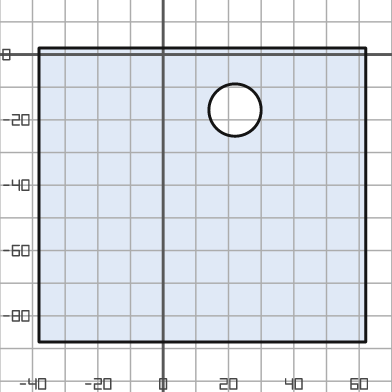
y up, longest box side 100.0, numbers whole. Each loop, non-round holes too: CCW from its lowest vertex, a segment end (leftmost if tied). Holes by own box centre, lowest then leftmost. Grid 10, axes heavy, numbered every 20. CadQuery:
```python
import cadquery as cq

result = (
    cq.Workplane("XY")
    .moveTo(-38.0, -88.0)
    .lineTo(62.0, -88.0)
    .lineTo(62.0, 2.0)
    .lineTo(-38.0, 2.0)
    .close()
    .moveTo(22.0, -17.0)
    .circle(8.0)
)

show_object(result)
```